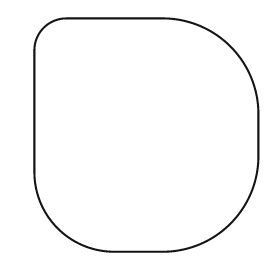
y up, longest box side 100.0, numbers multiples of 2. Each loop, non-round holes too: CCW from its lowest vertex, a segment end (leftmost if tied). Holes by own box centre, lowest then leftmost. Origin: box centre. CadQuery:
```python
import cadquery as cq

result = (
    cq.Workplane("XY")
    .moveTo(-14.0, -50.0)
    .lineTo(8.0, -50.0)
    .threePointArc((36.0, -38.0), (48.0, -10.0))
    .lineTo(48.0, 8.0)
    .threePointArc((36.0, 38.0), (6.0, 50.0))
    .lineTo(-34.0, 50.0)
    .threePointArc((-44.0, 46.0), (-48.0, 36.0))
    .lineTo(-48.0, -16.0)
    .threePointArc((-38.0, -40.0), (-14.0, -50.0))
    .close()
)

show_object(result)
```